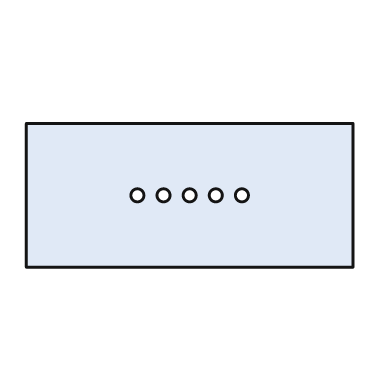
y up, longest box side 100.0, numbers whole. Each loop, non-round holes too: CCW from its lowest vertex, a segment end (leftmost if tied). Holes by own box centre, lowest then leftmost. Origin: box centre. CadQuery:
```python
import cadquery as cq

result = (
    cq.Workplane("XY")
    .moveTo(-50.0, -22.0)
    .lineTo(50.0, -22.0)
    .lineTo(50.0, 22.0)
    .lineTo(-50.0, 22.0)
    .close()
    .moveTo(-16.0, 0.0)
    .circle(2.0)
    .moveTo(-8.0, 0.0)
    .circle(2.0)
    .moveTo(0.0, 0.0)
    .circle(2.0)
    .moveTo(8.0, 0.0)
    .circle(2.0)
    .moveTo(16.0, 0.0)
    .circle(2.0)
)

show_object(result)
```